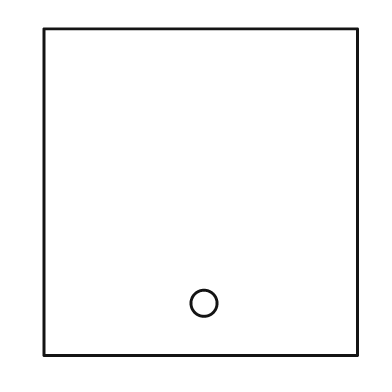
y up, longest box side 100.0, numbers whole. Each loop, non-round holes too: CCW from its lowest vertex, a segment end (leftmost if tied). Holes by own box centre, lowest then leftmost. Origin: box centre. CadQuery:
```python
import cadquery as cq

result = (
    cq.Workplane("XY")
    .moveTo(-48.0, -50.0)
    .lineTo(48.0, -50.0)
    .lineTo(48.0, 50.0)
    .lineTo(-48.0, 50.0)
    .close()
    .moveTo(1.0, -34.0)
    .circle(4.0)
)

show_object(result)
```